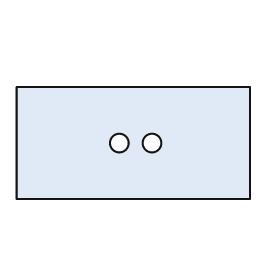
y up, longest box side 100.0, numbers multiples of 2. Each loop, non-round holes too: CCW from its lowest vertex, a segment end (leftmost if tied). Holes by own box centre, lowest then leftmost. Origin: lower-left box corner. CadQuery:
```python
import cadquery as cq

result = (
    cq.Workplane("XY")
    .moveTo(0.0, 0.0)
    .lineTo(100.0, 0.0)
    .lineTo(100.0, 48.0)
    .lineTo(0.0, 48.0)
    .close()
    .moveTo(44.0, 24.0)
    .circle(4.0)
    .moveTo(58.0, 24.0)
    .circle(4.0)
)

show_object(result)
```